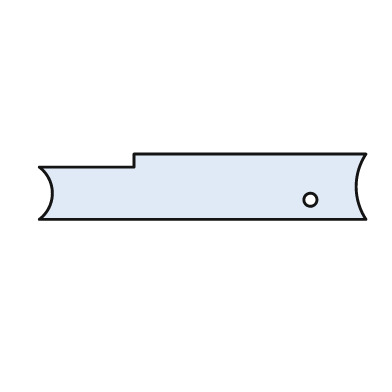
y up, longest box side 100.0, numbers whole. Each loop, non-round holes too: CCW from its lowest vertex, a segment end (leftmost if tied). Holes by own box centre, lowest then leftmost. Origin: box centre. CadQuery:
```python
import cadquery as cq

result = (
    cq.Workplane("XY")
    .moveTo(-50.0, -10.0)
    .lineTo(50.0, -10.0)
    .threePointArc((47.0, 0.0), (50.0, 10.0))
    .lineTo(-21.0, 10.0)
    .lineTo(-21.0, 6.0)
    .lineTo(-50.0, 6.0)
    .threePointArc((-46.0, -2.0), (-50.0, -10.0))
    .close()
    .moveTo(33.0, -4.0)
    .circle(2.0)
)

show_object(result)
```